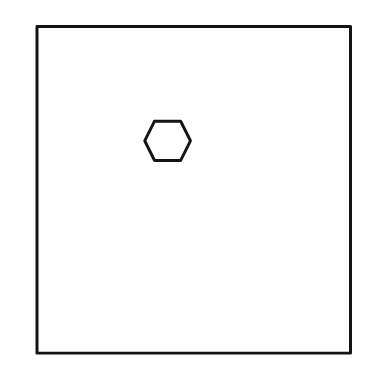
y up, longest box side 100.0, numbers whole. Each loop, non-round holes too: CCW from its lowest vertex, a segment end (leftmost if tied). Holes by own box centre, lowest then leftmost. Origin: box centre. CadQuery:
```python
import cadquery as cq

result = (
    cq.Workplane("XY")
    .moveTo(-48.0, -50.0)
    .lineTo(48.0, -50.0)
    .lineTo(48.0, 50.0)
    .lineTo(-48.0, 50.0)
    .close()
    .moveTo(-12.0, 9.0)
    .lineTo(-4.0, 9.0)
    .lineTo(-1.0, 15.0)
    .lineTo(-4.0, 21.0)
    .lineTo(-12.0, 21.0)
    .lineTo(-15.0, 15.0)
    .close()
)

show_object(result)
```